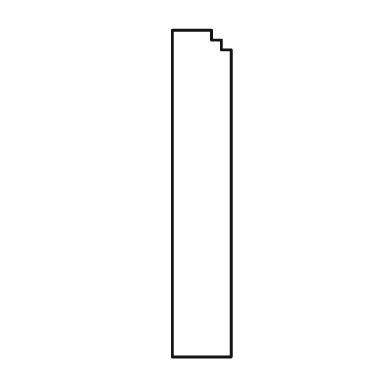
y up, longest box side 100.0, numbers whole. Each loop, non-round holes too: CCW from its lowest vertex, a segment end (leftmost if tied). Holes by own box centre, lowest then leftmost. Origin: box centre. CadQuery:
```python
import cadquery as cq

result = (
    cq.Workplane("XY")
    .moveTo(-9.0, -50.0)
    .lineTo(9.0, -50.0)
    .lineTo(9.0, 44.0)
    .lineTo(6.0, 44.0)
    .lineTo(6.0, 47.0)
    .lineTo(3.0, 47.0)
    .lineTo(3.0, 50.0)
    .lineTo(-9.0, 50.0)
    .close()
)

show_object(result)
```